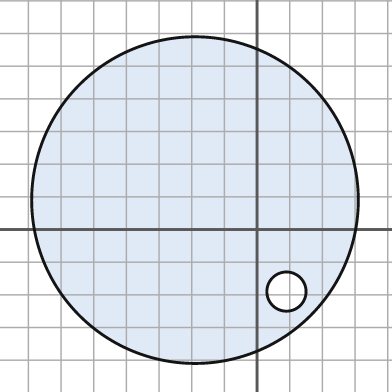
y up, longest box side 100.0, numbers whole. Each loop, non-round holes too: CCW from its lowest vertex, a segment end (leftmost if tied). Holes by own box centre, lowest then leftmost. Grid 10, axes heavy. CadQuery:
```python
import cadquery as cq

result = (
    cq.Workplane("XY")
    .moveTo(-19.0, 9.0)
    .circle(50.0)
    .moveTo(9.0, -19.0)
    .circle(6.0)
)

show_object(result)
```